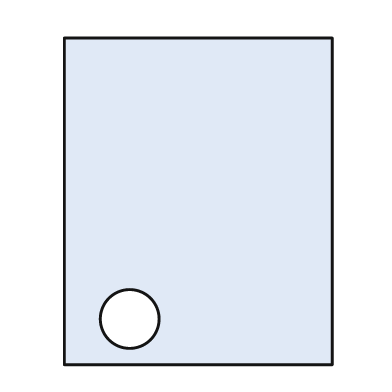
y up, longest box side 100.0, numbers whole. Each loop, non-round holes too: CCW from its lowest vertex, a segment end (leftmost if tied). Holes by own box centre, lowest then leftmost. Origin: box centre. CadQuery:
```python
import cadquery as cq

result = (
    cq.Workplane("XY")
    .moveTo(-41.0, -50.0)
    .lineTo(41.0, -50.0)
    .lineTo(41.0, 50.0)
    .lineTo(-41.0, 50.0)
    .close()
    .moveTo(-21.0, -36.0)
    .circle(9.0)
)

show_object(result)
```